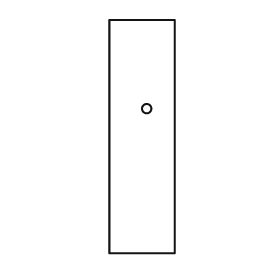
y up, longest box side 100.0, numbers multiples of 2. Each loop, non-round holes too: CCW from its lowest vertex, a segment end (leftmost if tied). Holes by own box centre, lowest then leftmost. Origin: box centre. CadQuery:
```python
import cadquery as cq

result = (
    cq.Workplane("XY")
    .moveTo(-14.0, -50.0)
    .lineTo(14.0, -50.0)
    .lineTo(14.0, 50.0)
    .lineTo(-14.0, 50.0)
    .close()
    .moveTo(2.0, 12.0)
    .circle(2.0)
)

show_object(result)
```